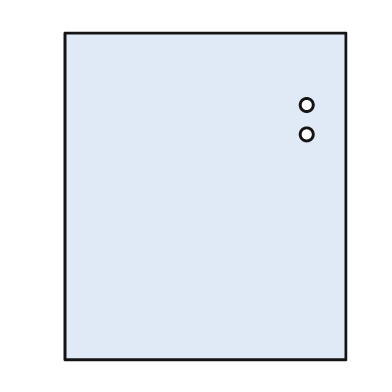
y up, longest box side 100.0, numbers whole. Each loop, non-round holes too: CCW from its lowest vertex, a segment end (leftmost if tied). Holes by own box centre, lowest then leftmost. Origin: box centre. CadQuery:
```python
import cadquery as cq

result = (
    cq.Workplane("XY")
    .moveTo(-43.0, -50.0)
    .lineTo(43.0, -50.0)
    .lineTo(43.0, 50.0)
    .lineTo(-43.0, 50.0)
    .close()
    .moveTo(31.0, 19.0)
    .circle(2.0)
    .moveTo(31.0, 28.0)
    .circle(2.0)
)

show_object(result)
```